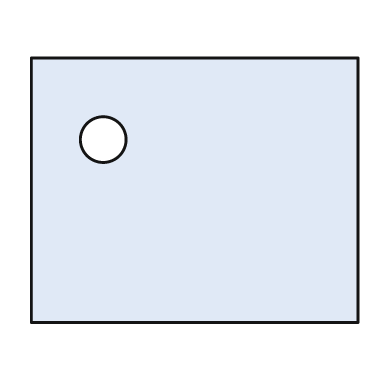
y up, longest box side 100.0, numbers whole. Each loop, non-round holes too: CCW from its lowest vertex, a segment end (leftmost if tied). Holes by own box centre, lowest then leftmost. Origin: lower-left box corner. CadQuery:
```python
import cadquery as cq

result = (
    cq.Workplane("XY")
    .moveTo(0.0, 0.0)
    .lineTo(100.0, 0.0)
    .lineTo(100.0, 81.0)
    .lineTo(0.0, 81.0)
    .close()
    .moveTo(22.0, 56.0)
    .circle(7.0)
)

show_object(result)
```